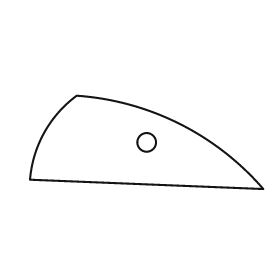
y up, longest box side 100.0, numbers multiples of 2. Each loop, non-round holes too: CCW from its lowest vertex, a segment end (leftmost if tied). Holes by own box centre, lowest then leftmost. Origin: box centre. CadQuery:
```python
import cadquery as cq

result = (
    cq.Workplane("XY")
    .moveTo(50.0, -20.0)
    .threePointArc((14.0, 8.0), (-30.0, 20.0))
    .threePointArc((-44.0, 4.0), (-50.0, -16.0))
    .close()
    .moveTo(0.0, 0.0)
    .circle(4.0)
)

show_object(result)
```